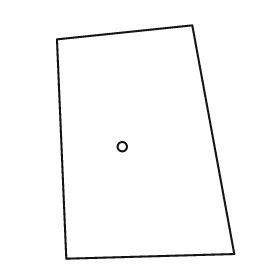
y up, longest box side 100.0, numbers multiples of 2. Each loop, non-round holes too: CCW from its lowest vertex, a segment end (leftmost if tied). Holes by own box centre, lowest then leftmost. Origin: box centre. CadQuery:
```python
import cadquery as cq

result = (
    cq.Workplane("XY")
    .moveTo(-34.0, -50.0)
    .lineTo(38.0, -48.0)
    .lineTo(20.0, 50.0)
    .lineTo(-38.0, 44.0)
    .close()
    .moveTo(-10.0, -2.0)
    .circle(2.0)
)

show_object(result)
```